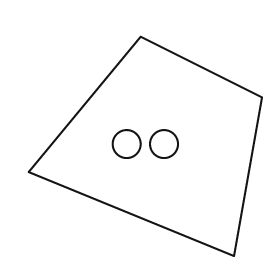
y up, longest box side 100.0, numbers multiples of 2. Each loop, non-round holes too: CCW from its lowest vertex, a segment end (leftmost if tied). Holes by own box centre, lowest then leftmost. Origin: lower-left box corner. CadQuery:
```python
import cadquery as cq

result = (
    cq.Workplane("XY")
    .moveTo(88.0, 0.0)
    .lineTo(100.0, 68.0)
    .lineTo(48.0, 94.0)
    .lineTo(0.0, 36.0)
    .close()
    .moveTo(42.0, 48.0)
    .circle(6.0)
    .moveTo(58.0, 48.0)
    .circle(6.0)
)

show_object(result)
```